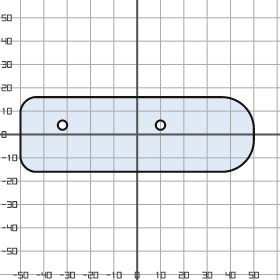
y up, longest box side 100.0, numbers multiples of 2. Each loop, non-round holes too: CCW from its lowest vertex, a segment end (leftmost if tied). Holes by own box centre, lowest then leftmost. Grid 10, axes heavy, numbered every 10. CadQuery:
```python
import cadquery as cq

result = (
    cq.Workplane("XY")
    .moveTo(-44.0, -16.0)
    .lineTo(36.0, -16.0)
    .threePointArc((46.0, -12.0), (50.0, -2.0))
    .lineTo(50.0, 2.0)
    .threePointArc((46.0, 12.0), (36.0, 16.0))
    .lineTo(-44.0, 16.0)
    .threePointArc((-48.0, 14.0), (-50.0, 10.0))
    .lineTo(-50.0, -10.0)
    .threePointArc((-48.0, -14.0), (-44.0, -16.0))
    .close()
    .moveTo(-32.0, 4.0)
    .circle(2.0)
    .moveTo(10.0, 4.0)
    .circle(2.0)
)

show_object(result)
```